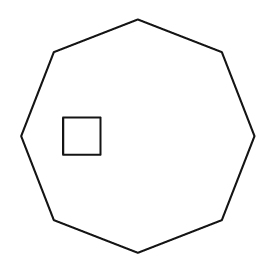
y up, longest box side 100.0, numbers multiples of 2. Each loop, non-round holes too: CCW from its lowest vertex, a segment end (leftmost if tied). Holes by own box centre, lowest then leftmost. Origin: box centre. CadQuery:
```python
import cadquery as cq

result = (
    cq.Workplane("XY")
    .moveTo(0.0, -50.0)
    .lineTo(36.0, -36.0)
    .lineTo(50.0, 0.0)
    .lineTo(36.0, 36.0)
    .lineTo(0.0, 50.0)
    .lineTo(-36.0, 36.0)
    .lineTo(-50.0, 0.0)
    .lineTo(-36.0, -36.0)
    .close()
    .moveTo(-32.0, -8.0)
    .lineTo(-16.0, -8.0)
    .lineTo(-16.0, 8.0)
    .lineTo(-32.0, 8.0)
    .close()
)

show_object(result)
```